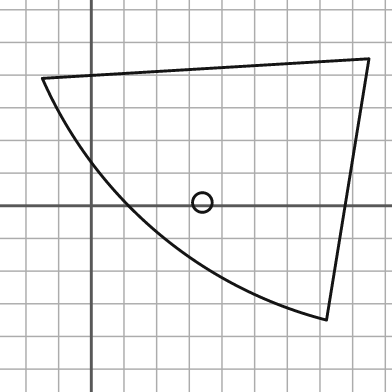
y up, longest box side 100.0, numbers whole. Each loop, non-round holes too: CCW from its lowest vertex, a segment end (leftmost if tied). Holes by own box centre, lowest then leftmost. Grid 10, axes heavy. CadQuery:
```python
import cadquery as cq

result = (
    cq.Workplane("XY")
    .moveTo(72.0, -35.0)
    .lineTo(85.0, 45.0)
    .lineTo(-15.0, 39.0)
    .threePointArc((20.0, -8.0), (72.0, -35.0))
    .close()
    .moveTo(34.0, 1.0)
    .circle(3.0)
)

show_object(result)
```